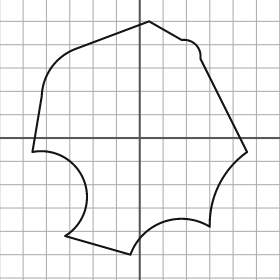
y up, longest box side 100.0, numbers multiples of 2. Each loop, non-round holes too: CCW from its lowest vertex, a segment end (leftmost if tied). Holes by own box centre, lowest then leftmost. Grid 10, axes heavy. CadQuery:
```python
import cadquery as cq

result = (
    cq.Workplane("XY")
    .moveTo(-4.0, -50.0)
    .threePointArc((10.0, -36.0), (30.0, -38.0))
    .threePointArc((34.0, -20.0), (46.0, -6.0))
    .lineTo(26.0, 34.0)
    .threePointArc((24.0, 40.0), (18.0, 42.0))
    .lineTo(4.0, 50.0)
    .lineTo(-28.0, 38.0)
    .threePointArc((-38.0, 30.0), (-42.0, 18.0))
    .lineTo(-46.0, -6.0)
    .threePointArc((-24.0, -18.0), (-32.0, -42.0))
    .close()
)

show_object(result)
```